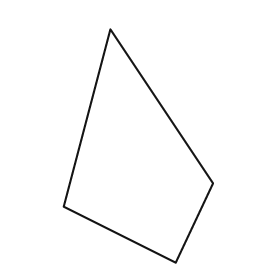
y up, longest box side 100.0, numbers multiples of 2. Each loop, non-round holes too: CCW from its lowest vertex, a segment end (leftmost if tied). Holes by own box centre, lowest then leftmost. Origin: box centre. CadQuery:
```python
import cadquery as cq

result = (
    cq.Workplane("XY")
    .moveTo(16.0, -50.0)
    .lineTo(32.0, -16.0)
    .lineTo(-12.0, 50.0)
    .lineTo(-32.0, -26.0)
    .close()
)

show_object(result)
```